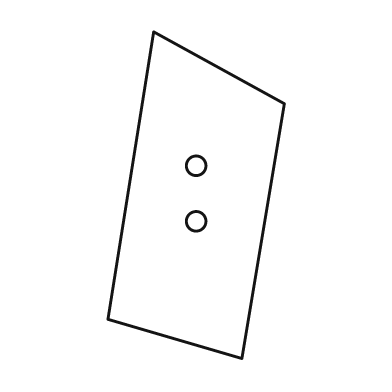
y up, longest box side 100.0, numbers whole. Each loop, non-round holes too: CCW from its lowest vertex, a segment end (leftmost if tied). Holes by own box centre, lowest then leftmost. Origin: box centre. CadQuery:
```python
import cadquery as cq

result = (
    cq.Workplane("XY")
    .moveTo(14.0, -50.0)
    .lineTo(27.0, 28.0)
    .lineTo(-13.0, 50.0)
    .lineTo(-27.0, -38.0)
    .close()
    .moveTo(0.0, -8.0)
    .circle(3.0)
    .moveTo(0.0, 9.0)
    .circle(3.0)
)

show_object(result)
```